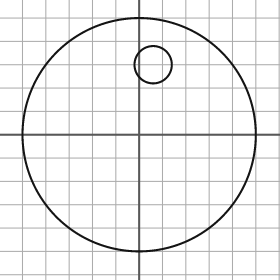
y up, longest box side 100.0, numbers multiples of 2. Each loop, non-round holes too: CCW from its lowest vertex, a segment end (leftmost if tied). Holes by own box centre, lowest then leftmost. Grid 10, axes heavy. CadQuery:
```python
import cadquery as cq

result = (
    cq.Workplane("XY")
    .moveTo(0.0, 0.0)
    .circle(50.0)
    .moveTo(6.0, 30.0)
    .circle(8.0)
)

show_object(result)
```